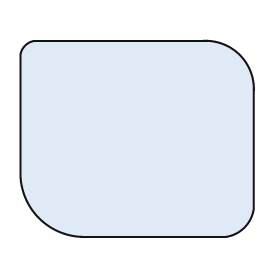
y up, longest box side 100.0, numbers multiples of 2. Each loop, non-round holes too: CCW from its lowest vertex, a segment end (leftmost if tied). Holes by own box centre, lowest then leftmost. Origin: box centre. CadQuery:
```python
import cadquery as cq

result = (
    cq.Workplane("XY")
    .moveTo(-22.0, -42.0)
    .lineTo(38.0, -42.0)
    .threePointArc((46.0, -38.0), (50.0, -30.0))
    .lineTo(50.0, 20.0)
    .threePointArc((44.0, 36.0), (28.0, 42.0))
    .lineTo(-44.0, 42.0)
    .threePointArc((-48.0, 40.0), (-50.0, 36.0))
    .lineTo(-50.0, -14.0)
    .threePointArc((-42.0, -34.0), (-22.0, -42.0))
    .close()
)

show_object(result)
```